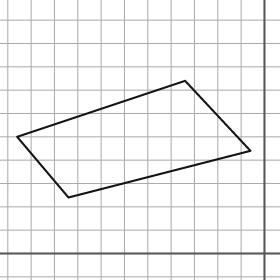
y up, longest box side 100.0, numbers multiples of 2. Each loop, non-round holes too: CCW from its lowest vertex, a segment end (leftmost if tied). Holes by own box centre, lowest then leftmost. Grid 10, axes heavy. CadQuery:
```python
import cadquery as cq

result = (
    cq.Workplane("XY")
    .moveTo(-84.0, 24.0)
    .lineTo(-6.0, 44.0)
    .lineTo(-34.0, 74.0)
    .lineTo(-106.0, 50.0)
    .close()
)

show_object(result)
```